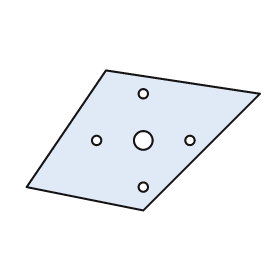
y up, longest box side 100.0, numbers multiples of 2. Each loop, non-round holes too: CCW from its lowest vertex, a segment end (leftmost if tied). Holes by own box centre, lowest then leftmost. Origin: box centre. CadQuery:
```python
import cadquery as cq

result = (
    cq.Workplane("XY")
    .moveTo(0.0, -30.0)
    .lineTo(50.0, 20.0)
    .lineTo(-16.0, 30.0)
    .lineTo(-50.0, -20.0)
    .close()
    .moveTo(0.0, -20.0)
    .circle(2.0)
    .moveTo(-20.0, 0.0)
    .circle(2.0)
    .moveTo(0.0, 0.0)
    .circle(4.0)
    .moveTo(20.0, 0.0)
    .circle(2.0)
    .moveTo(0.0, 20.0)
    .circle(2.0)
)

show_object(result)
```